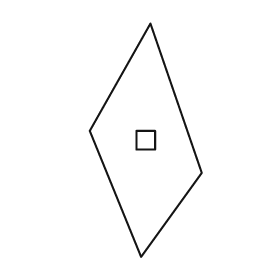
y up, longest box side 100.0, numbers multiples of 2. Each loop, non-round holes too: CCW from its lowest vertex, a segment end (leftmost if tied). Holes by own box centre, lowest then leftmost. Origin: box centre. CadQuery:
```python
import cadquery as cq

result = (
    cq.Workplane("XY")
    .moveTo(-2.0, -50.0)
    .lineTo(24.0, -14.0)
    .lineTo(2.0, 50.0)
    .lineTo(-24.0, 4.0)
    .close()
    .moveTo(-4.0, -4.0)
    .lineTo(4.0, -4.0)
    .lineTo(4.0, 4.0)
    .lineTo(-4.0, 4.0)
    .close()
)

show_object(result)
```